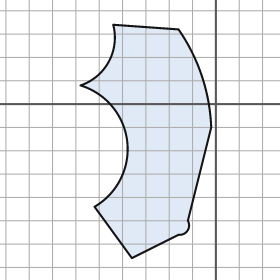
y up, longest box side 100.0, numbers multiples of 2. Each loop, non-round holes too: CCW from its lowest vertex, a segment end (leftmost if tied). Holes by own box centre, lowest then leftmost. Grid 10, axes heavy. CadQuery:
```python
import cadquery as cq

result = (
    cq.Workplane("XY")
    .moveTo(-36.0, -66.0)
    .lineTo(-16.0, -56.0)
    .threePointArc((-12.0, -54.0), (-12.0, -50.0))
    .lineTo(-2.0, -10.0)
    .threePointArc((-6.0, 12.0), (-16.0, 32.0))
    .lineTo(-44.0, 34.0)
    .threePointArc((-46.0, 18.0), (-58.0, 8.0))
    .threePointArc((-38.0, -16.0), (-52.0, -44.0))
    .close()
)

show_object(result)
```